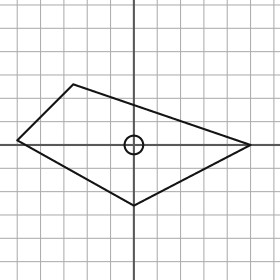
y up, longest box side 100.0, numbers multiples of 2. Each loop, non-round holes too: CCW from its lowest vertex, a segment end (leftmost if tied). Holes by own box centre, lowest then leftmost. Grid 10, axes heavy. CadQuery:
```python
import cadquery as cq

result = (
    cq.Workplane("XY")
    .moveTo(0.0, -26.0)
    .lineTo(50.0, 0.0)
    .lineTo(-26.0, 26.0)
    .lineTo(-50.0, 2.0)
    .close()
    .moveTo(0.0, 0.0)
    .circle(4.0)
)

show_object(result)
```